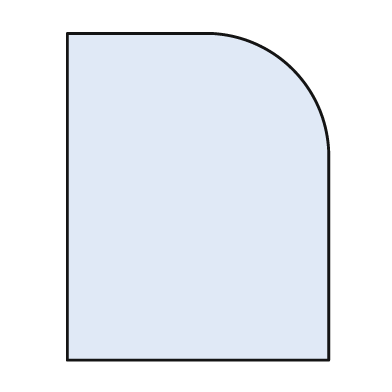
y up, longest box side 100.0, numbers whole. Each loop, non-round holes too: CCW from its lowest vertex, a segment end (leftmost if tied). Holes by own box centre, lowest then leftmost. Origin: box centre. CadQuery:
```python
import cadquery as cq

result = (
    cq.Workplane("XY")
    .moveTo(-40.0, -50.0)
    .lineTo(40.0, -50.0)
    .lineTo(40.0, 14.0)
    .threePointArc((29.0, 39.0), (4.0, 50.0))
    .lineTo(-40.0, 50.0)
    .close()
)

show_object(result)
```